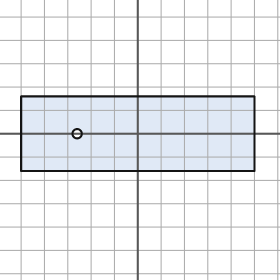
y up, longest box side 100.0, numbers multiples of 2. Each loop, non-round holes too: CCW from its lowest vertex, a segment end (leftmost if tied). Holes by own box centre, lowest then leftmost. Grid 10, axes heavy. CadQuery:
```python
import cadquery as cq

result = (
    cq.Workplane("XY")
    .moveTo(-50.0, -16.0)
    .lineTo(50.0, -16.0)
    .lineTo(50.0, 16.0)
    .lineTo(-50.0, 16.0)
    .close()
    .moveTo(-26.0, 0.0)
    .circle(2.0)
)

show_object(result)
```